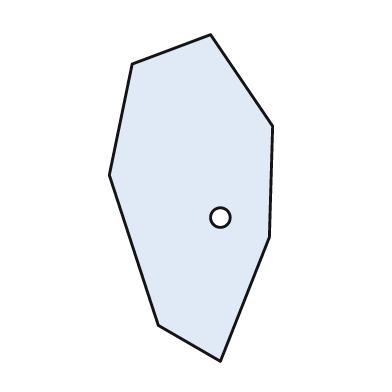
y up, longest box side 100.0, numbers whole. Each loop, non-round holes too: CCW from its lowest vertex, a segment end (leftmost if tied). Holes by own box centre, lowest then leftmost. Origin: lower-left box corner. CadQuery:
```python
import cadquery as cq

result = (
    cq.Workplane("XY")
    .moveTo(34.0, 0.0)
    .lineTo(49.0, 38.0)
    .lineTo(50.0, 72.0)
    .lineTo(31.0, 100.0)
    .lineTo(7.0, 91.0)
    .lineTo(0.0, 57.0)
    .lineTo(15.0, 11.0)
    .close()
    .moveTo(34.0, 44.0)
    .circle(3.0)
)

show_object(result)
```